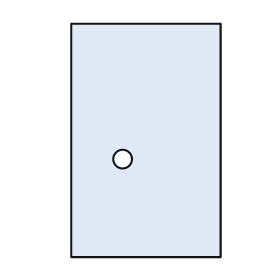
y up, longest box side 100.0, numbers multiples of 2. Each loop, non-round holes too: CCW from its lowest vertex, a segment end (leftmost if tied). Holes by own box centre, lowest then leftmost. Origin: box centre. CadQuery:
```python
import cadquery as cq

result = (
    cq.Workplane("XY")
    .moveTo(-32.0, -50.0)
    .lineTo(32.0, -50.0)
    .lineTo(32.0, 50.0)
    .lineTo(-32.0, 50.0)
    .close()
    .moveTo(-10.0, -8.0)
    .circle(4.0)
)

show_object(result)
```